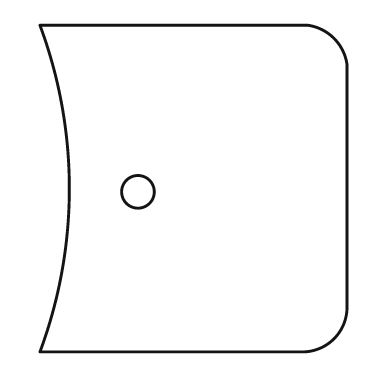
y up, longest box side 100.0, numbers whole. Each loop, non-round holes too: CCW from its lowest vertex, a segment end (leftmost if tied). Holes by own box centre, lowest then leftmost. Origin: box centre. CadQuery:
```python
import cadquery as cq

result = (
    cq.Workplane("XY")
    .moveTo(-47.0, -50.0)
    .lineTo(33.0, -50.0)
    .threePointArc((43.0, -46.0), (47.0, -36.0))
    .lineTo(47.0, 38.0)
    .threePointArc((43.0, 46.0), (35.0, 50.0))
    .lineTo(-47.0, 50.0)
    .threePointArc((-38.0, 0.0), (-47.0, -50.0))
    .close()
    .moveTo(-17.0, -1.0)
    .circle(5.0)
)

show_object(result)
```